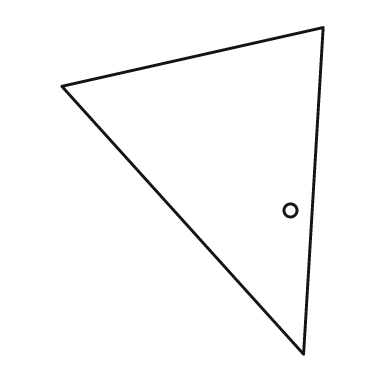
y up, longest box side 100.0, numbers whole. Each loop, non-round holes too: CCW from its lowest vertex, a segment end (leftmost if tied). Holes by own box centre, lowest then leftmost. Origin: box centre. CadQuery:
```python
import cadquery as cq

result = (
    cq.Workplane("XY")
    .moveTo(34.0, -50.0)
    .lineTo(40.0, 50.0)
    .lineTo(-40.0, 32.0)
    .close()
    .moveTo(30.0, -6.0)
    .circle(2.0)
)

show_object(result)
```